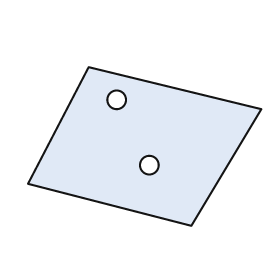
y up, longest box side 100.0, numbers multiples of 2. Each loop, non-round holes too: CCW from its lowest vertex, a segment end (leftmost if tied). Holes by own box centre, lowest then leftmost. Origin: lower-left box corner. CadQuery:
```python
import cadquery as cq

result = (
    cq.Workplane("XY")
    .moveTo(70.0, 0.0)
    .lineTo(100.0, 50.0)
    .lineTo(26.0, 68.0)
    .lineTo(0.0, 18.0)
    .close()
    .moveTo(52.0, 26.0)
    .circle(4.0)
    .moveTo(38.0, 54.0)
    .circle(4.0)
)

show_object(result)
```